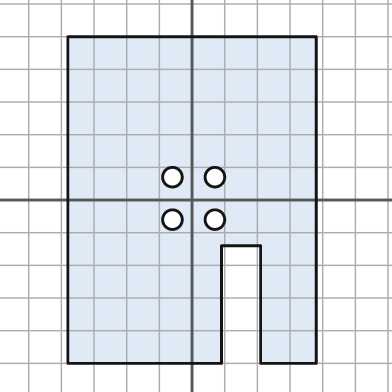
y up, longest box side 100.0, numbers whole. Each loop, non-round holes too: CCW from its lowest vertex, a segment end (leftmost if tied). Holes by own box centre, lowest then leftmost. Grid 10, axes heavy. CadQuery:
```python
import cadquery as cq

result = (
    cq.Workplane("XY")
    .moveTo(-38.0, -50.0)
    .lineTo(9.0, -50.0)
    .lineTo(9.0, -14.0)
    .lineTo(21.0, -14.0)
    .lineTo(21.0, -50.0)
    .lineTo(38.0, -50.0)
    .lineTo(38.0, 50.0)
    .lineTo(-38.0, 50.0)
    .close()
    .moveTo(-6.0, -6.0)
    .circle(3.0)
    .moveTo(7.0, -6.0)
    .circle(3.0)
    .moveTo(-6.0, 7.0)
    .circle(3.0)
    .moveTo(7.0, 7.0)
    .circle(3.0)
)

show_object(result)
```